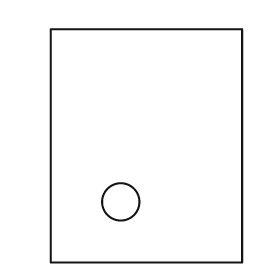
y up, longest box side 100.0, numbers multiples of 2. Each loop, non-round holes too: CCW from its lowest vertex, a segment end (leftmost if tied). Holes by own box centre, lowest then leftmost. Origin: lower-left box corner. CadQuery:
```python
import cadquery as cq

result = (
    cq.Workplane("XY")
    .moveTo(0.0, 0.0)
    .lineTo(82.0, 0.0)
    .lineTo(82.0, 100.0)
    .lineTo(0.0, 100.0)
    .close()
    .moveTo(30.0, 26.0)
    .circle(8.0)
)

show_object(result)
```